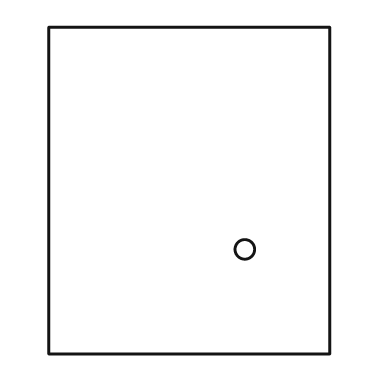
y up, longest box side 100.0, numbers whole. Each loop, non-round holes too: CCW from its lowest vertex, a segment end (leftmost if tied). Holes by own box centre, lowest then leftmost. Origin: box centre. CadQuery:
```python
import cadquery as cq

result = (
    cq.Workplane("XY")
    .moveTo(-43.0, -50.0)
    .lineTo(43.0, -50.0)
    .lineTo(43.0, 50.0)
    .lineTo(-43.0, 50.0)
    .close()
    .moveTo(17.0, -18.0)
    .circle(3.0)
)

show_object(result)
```